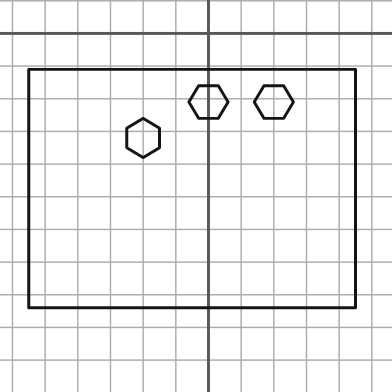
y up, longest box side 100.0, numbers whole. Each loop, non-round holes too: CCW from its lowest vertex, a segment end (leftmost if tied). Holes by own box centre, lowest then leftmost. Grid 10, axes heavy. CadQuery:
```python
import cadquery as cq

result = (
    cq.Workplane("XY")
    .moveTo(-55.0, -84.0)
    .lineTo(45.0, -84.0)
    .lineTo(45.0, -11.0)
    .lineTo(-55.0, -11.0)
    .close()
    .moveTo(-20.0, -38.0)
    .lineTo(-15.0, -35.0)
    .lineTo(-15.0, -29.0)
    .lineTo(-20.0, -26.0)
    .lineTo(-25.0, -29.0)
    .lineTo(-25.0, -35.0)
    .close()
    .moveTo(-3.0, -26.0)
    .lineTo(3.0, -26.0)
    .lineTo(6.0, -21.0)
    .lineTo(3.0, -16.0)
    .lineTo(-3.0, -16.0)
    .lineTo(-6.0, -21.0)
    .close()
    .moveTo(17.0, -26.0)
    .lineTo(23.0, -26.0)
    .lineTo(26.0, -21.0)
    .lineTo(23.0, -16.0)
    .lineTo(17.0, -16.0)
    .lineTo(14.0, -21.0)
    .close()
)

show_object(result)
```